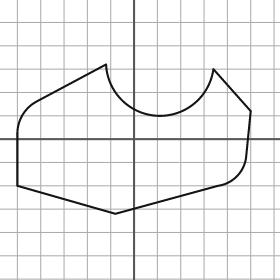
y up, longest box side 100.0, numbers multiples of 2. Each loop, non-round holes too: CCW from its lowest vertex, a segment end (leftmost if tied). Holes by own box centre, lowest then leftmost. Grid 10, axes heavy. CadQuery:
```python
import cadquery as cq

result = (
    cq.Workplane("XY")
    .moveTo(-8.0, -32.0)
    .lineTo(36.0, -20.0)
    .threePointArc((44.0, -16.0), (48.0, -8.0))
    .lineTo(50.0, 12.0)
    .lineTo(34.0, 30.0)
    .threePointArc((10.0, 10.0), (-12.0, 32.0))
    .lineTo(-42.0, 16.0)
    .threePointArc((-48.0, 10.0), (-50.0, 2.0))
    .lineTo(-50.0, -20.0)
    .close()
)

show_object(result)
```